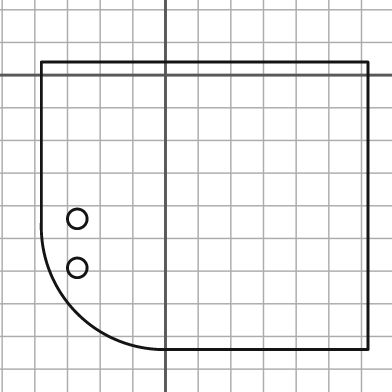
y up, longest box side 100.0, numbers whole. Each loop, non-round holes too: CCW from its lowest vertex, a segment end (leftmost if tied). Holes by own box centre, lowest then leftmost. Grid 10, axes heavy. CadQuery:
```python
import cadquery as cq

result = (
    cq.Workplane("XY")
    .moveTo(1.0, -84.0)
    .lineTo(62.0, -84.0)
    .lineTo(62.0, 4.0)
    .lineTo(-38.0, 4.0)
    .lineTo(-38.0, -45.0)
    .threePointArc((-27.0, -73.0), (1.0, -84.0))
    .close()
    .moveTo(-27.0, -59.0)
    .circle(3.0)
    .moveTo(-27.0, -44.0)
    .circle(3.0)
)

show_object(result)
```